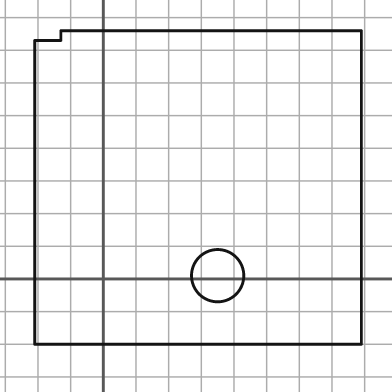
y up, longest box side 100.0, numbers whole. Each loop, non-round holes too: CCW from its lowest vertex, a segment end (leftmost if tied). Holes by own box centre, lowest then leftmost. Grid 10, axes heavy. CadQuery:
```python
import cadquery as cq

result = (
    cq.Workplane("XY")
    .moveTo(-21.0, -20.0)
    .lineTo(79.0, -20.0)
    .lineTo(79.0, 76.0)
    .lineTo(-13.0, 76.0)
    .lineTo(-13.0, 73.0)
    .lineTo(-21.0, 73.0)
    .close()
    .moveTo(35.0, 1.0)
    .circle(8.0)
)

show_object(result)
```